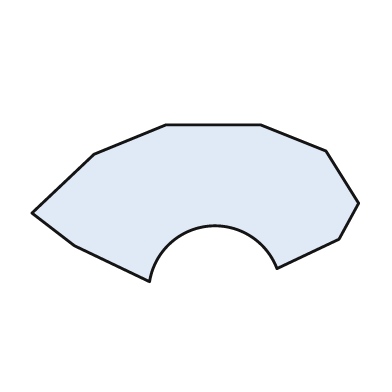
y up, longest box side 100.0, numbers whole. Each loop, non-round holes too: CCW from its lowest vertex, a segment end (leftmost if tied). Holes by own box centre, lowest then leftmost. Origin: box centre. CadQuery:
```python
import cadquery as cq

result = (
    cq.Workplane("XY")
    .moveTo(-14.0, -24.0)
    .threePointArc((4.0, -7.0), (25.0, -20.0))
    .lineTo(44.0, -11.0)
    .lineTo(50.0, 0.0)
    .lineTo(40.0, 16.0)
    .lineTo(20.0, 24.0)
    .lineTo(-9.0, 24.0)
    .lineTo(-31.0, 15.0)
    .lineTo(-50.0, -3.0)
    .lineTo(-37.0, -13.0)
    .close()
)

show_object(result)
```